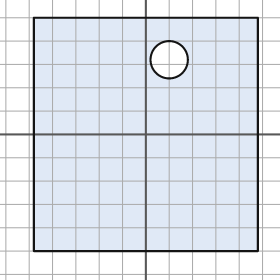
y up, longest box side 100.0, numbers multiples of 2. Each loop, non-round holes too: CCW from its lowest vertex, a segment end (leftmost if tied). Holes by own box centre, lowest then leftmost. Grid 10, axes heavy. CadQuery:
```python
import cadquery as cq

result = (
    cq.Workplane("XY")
    .moveTo(-48.0, -50.0)
    .lineTo(48.0, -50.0)
    .lineTo(48.0, 50.0)
    .lineTo(-48.0, 50.0)
    .close()
    .moveTo(10.0, 32.0)
    .circle(8.0)
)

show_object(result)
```